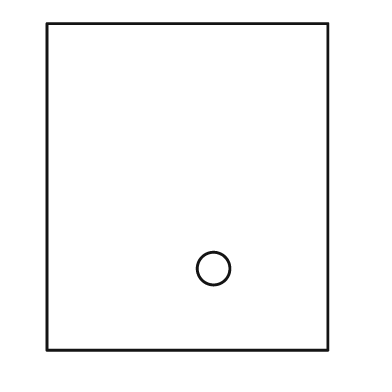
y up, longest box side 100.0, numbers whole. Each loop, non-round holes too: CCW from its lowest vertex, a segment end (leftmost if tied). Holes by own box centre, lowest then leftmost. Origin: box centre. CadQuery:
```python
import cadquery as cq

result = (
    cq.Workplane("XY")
    .moveTo(-43.0, -50.0)
    .lineTo(43.0, -50.0)
    .lineTo(43.0, 50.0)
    .lineTo(-43.0, 50.0)
    .close()
    .moveTo(8.0, -25.0)
    .circle(5.0)
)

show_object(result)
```